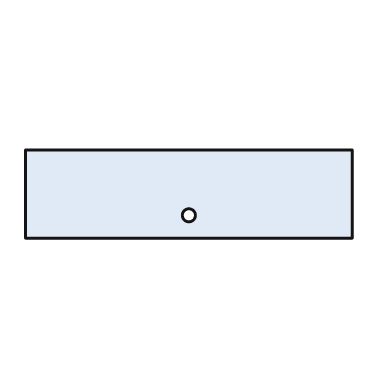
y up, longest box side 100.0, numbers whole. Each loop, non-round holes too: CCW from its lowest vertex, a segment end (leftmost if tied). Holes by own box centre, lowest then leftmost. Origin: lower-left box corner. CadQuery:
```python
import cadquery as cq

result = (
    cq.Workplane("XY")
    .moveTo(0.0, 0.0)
    .lineTo(100.0, 0.0)
    .lineTo(100.0, 27.0)
    .lineTo(0.0, 27.0)
    .close()
    .moveTo(50.0, 7.0)
    .circle(2.0)
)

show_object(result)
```